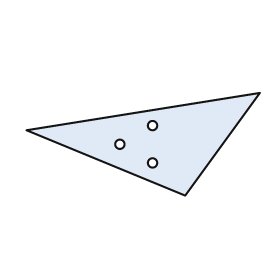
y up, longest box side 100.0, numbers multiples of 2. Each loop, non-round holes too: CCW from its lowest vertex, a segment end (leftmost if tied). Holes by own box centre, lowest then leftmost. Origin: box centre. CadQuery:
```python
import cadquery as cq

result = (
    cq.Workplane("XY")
    .moveTo(18.0, -22.0)
    .lineTo(50.0, 22.0)
    .lineTo(-50.0, 6.0)
    .close()
    .moveTo(4.0, -8.0)
    .circle(2.0)
    .moveTo(-10.0, 0.0)
    .circle(2.0)
    .moveTo(4.0, 8.0)
    .circle(2.0)
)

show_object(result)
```